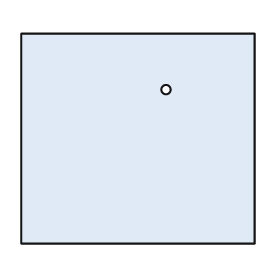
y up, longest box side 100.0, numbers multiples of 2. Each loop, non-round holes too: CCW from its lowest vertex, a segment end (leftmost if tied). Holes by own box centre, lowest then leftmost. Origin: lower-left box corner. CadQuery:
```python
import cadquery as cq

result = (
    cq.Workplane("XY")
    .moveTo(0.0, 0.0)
    .lineTo(100.0, 0.0)
    .lineTo(100.0, 90.0)
    .lineTo(0.0, 90.0)
    .close()
    .moveTo(62.0, 66.0)
    .circle(2.0)
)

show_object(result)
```